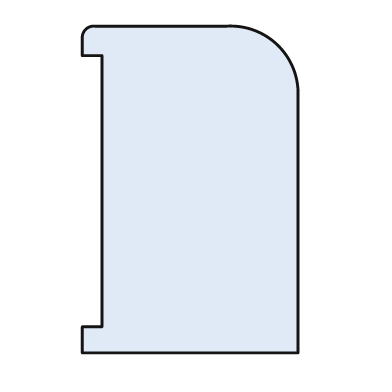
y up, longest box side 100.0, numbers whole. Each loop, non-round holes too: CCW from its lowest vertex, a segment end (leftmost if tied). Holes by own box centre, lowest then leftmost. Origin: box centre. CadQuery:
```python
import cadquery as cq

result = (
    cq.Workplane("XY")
    .moveTo(-33.0, -50.0)
    .lineTo(33.0, -50.0)
    .lineTo(33.0, 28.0)
    .threePointArc((27.0, 44.0), (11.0, 50.0))
    .lineTo(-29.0, 50.0)
    .threePointArc((-32.0, 49.0), (-33.0, 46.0))
    .lineTo(-33.0, 41.0)
    .lineTo(-27.0, 41.0)
    .lineTo(-27.0, -42.0)
    .lineTo(-33.0, -42.0)
    .close()
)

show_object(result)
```